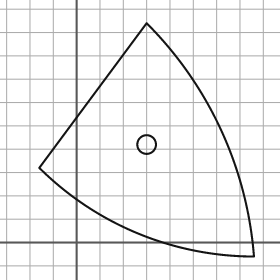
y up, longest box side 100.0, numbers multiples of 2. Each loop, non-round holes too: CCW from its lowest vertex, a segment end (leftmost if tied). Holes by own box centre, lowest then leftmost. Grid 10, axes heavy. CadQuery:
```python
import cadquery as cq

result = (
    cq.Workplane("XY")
    .moveTo(76.0, -6.0)
    .threePointArc((62.0, 48.0), (30.0, 94.0))
    .lineTo(-16.0, 32.0)
    .threePointArc((26.0, 4.0), (76.0, -6.0))
    .close()
    .moveTo(30.0, 42.0)
    .circle(4.0)
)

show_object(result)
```